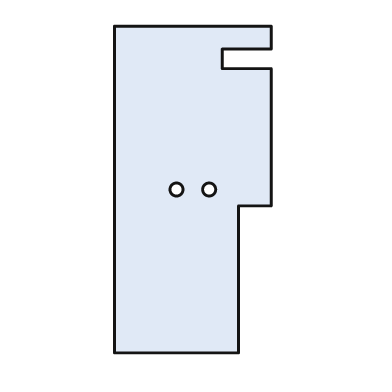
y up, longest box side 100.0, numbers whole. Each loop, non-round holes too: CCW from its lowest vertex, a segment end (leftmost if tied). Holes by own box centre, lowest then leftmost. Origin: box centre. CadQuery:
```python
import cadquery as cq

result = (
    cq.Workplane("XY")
    .moveTo(-24.0, -50.0)
    .lineTo(14.0, -50.0)
    .lineTo(14.0, -5.0)
    .lineTo(24.0, -5.0)
    .lineTo(24.0, 37.0)
    .lineTo(9.0, 37.0)
    .lineTo(9.0, 43.0)
    .lineTo(24.0, 43.0)
    .lineTo(24.0, 50.0)
    .lineTo(-24.0, 50.0)
    .close()
    .moveTo(-5.0, 0.0)
    .circle(2.0)
    .moveTo(5.0, 0.0)
    .circle(2.0)
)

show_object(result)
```